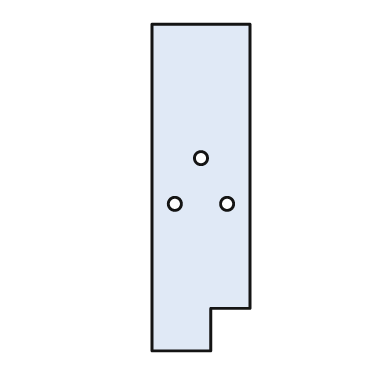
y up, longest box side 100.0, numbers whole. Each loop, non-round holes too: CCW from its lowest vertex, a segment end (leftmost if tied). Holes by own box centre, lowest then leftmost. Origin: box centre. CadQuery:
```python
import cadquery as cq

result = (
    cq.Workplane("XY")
    .moveTo(-15.0, -50.0)
    .lineTo(3.0, -50.0)
    .lineTo(3.0, -37.0)
    .lineTo(15.0, -37.0)
    .lineTo(15.0, 50.0)
    .lineTo(-15.0, 50.0)
    .close()
    .moveTo(-8.0, -5.0)
    .circle(2.0)
    .moveTo(8.0, -5.0)
    .circle(2.0)
    .moveTo(0.0, 9.0)
    .circle(2.0)
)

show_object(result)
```